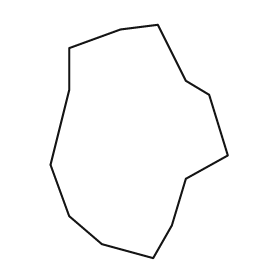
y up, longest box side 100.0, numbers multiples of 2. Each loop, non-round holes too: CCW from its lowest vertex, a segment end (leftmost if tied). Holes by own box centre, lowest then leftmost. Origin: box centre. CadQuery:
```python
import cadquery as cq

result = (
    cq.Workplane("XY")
    .moveTo(6.0, -50.0)
    .lineTo(14.0, -36.0)
    .lineTo(20.0, -16.0)
    .lineTo(38.0, -6.0)
    .lineTo(30.0, 20.0)
    .lineTo(20.0, 26.0)
    .lineTo(8.0, 50.0)
    .lineTo(-8.0, 48.0)
    .lineTo(-30.0, 40.0)
    .lineTo(-30.0, 22.0)
    .lineTo(-38.0, -10.0)
    .lineTo(-30.0, -32.0)
    .lineTo(-16.0, -44.0)
    .close()
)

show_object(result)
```